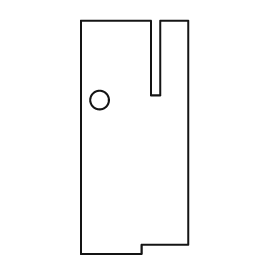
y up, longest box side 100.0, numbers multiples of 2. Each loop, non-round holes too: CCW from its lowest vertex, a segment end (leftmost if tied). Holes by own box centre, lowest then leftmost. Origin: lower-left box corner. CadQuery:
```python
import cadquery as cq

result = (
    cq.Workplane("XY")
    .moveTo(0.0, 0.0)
    .lineTo(26.0, 0.0)
    .lineTo(26.0, 4.0)
    .lineTo(46.0, 4.0)
    .lineTo(46.0, 100.0)
    .lineTo(34.0, 100.0)
    .lineTo(34.0, 68.0)
    .lineTo(30.0, 68.0)
    .lineTo(30.0, 100.0)
    .lineTo(0.0, 100.0)
    .close()
    .moveTo(8.0, 66.0)
    .circle(4.0)
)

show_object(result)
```